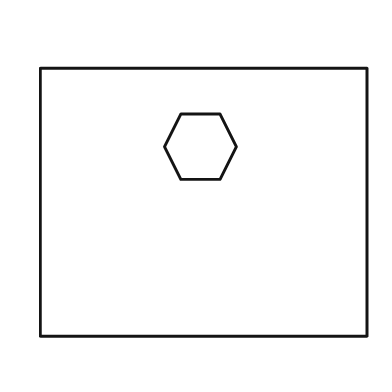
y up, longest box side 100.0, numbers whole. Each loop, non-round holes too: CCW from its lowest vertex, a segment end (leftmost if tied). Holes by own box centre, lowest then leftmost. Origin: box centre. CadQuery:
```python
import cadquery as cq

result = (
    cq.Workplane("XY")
    .moveTo(-50.0, -41.0)
    .lineTo(50.0, -41.0)
    .lineTo(50.0, 41.0)
    .lineTo(-50.0, 41.0)
    .close()
    .moveTo(-7.0, 7.0)
    .lineTo(5.0, 7.0)
    .lineTo(10.0, 17.0)
    .lineTo(5.0, 27.0)
    .lineTo(-7.0, 27.0)
    .lineTo(-12.0, 17.0)
    .close()
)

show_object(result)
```